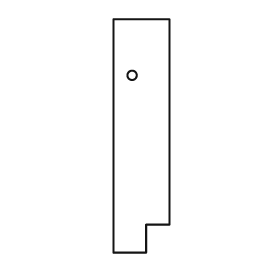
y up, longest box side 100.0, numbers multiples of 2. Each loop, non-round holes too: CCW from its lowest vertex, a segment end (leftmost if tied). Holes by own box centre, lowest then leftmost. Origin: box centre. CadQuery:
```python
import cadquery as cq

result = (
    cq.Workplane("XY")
    .moveTo(-12.0, -50.0)
    .lineTo(2.0, -50.0)
    .lineTo(2.0, -38.0)
    .lineTo(12.0, -38.0)
    .lineTo(12.0, 50.0)
    .lineTo(-12.0, 50.0)
    .close()
    .moveTo(-4.0, 26.0)
    .circle(2.0)
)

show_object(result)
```